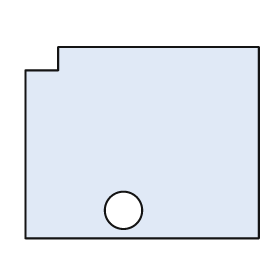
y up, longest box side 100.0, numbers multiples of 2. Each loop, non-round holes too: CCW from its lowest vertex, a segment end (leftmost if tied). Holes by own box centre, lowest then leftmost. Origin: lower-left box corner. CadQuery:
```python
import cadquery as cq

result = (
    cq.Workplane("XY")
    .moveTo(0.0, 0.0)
    .lineTo(100.0, 0.0)
    .lineTo(100.0, 82.0)
    .lineTo(14.0, 82.0)
    .lineTo(14.0, 72.0)
    .lineTo(0.0, 72.0)
    .close()
    .moveTo(42.0, 12.0)
    .circle(8.0)
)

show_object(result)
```